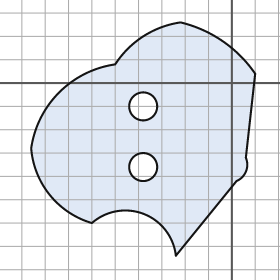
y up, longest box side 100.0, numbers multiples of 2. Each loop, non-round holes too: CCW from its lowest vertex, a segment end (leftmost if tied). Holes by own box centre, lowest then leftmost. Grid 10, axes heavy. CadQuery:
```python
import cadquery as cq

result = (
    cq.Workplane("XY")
    .moveTo(-24.0, -74.0)
    .lineTo(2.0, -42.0)
    .threePointArc((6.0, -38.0), (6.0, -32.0))
    .lineTo(10.0, 4.0)
    .threePointArc((-4.0, 18.0), (-22.0, 26.0))
    .threePointArc((-38.0, 20.0), (-50.0, 8.0))
    .threePointArc((-74.0, -4.0), (-86.0, -28.0))
    .threePointArc((-78.0, -48.0), (-60.0, -60.0))
    .threePointArc((-38.0, -56.0), (-24.0, -74.0))
    .close()
    .moveTo(-38.0, -36.0)
    .circle(6.0)
    .moveTo(-38.0, -10.0)
    .circle(6.0)
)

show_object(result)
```